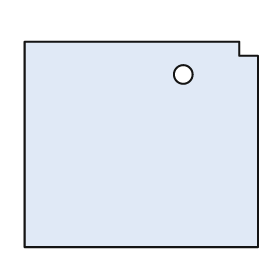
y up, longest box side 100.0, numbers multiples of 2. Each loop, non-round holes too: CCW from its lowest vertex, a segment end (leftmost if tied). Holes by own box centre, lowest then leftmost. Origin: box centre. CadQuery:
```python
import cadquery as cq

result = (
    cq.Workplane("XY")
    .moveTo(-50.0, -44.0)
    .lineTo(50.0, -44.0)
    .lineTo(50.0, 38.0)
    .lineTo(42.0, 38.0)
    .lineTo(42.0, 44.0)
    .lineTo(-50.0, 44.0)
    .close()
    .moveTo(18.0, 30.0)
    .circle(4.0)
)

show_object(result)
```